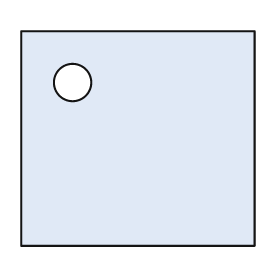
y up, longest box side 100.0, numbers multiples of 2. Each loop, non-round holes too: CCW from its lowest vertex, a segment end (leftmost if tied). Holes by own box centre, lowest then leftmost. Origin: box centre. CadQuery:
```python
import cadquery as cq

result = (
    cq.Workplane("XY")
    .moveTo(-50.0, -46.0)
    .lineTo(50.0, -46.0)
    .lineTo(50.0, 46.0)
    .lineTo(-50.0, 46.0)
    .close()
    .moveTo(-28.0, 24.0)
    .circle(8.0)
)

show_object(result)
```